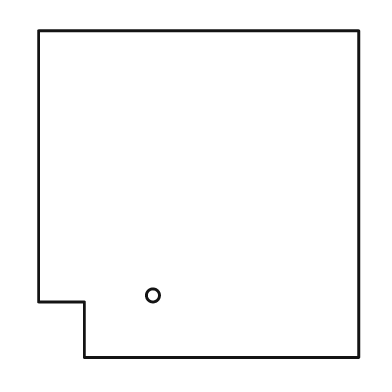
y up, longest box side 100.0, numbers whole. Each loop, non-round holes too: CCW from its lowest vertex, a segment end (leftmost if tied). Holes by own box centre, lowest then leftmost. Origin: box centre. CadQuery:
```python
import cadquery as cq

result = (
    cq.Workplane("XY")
    .moveTo(-35.0, -50.0)
    .lineTo(49.0, -50.0)
    .lineTo(49.0, 50.0)
    .lineTo(-49.0, 50.0)
    .lineTo(-49.0, -33.0)
    .lineTo(-35.0, -33.0)
    .close()
    .moveTo(-14.0, -31.0)
    .circle(2.0)
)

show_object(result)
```